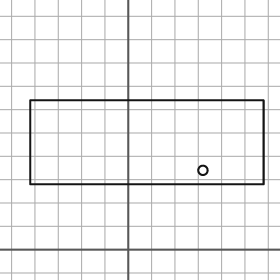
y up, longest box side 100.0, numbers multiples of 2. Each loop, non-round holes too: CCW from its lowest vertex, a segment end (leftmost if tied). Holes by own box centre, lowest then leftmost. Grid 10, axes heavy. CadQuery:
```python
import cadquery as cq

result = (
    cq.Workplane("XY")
    .moveTo(-42.0, 28.0)
    .lineTo(58.0, 28.0)
    .lineTo(58.0, 64.0)
    .lineTo(-42.0, 64.0)
    .close()
    .moveTo(32.0, 34.0)
    .circle(2.0)
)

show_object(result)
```